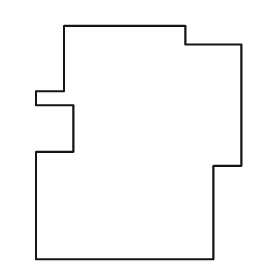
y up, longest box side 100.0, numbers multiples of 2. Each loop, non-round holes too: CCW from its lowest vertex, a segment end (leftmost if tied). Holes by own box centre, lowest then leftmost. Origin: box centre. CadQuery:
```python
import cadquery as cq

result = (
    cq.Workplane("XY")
    .moveTo(-44.0, -50.0)
    .lineTo(32.0, -50.0)
    .lineTo(32.0, -10.0)
    .lineTo(44.0, -10.0)
    .lineTo(44.0, 42.0)
    .lineTo(20.0, 42.0)
    .lineTo(20.0, 50.0)
    .lineTo(-32.0, 50.0)
    .lineTo(-32.0, 22.0)
    .lineTo(-44.0, 22.0)
    .lineTo(-44.0, 16.0)
    .lineTo(-28.0, 16.0)
    .lineTo(-28.0, -4.0)
    .lineTo(-44.0, -4.0)
    .close()
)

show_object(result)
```